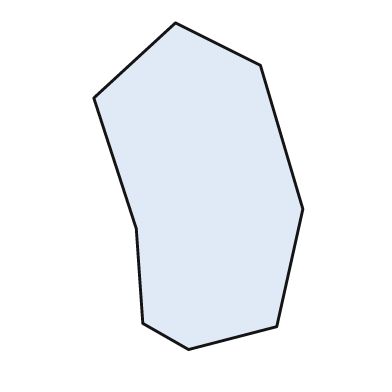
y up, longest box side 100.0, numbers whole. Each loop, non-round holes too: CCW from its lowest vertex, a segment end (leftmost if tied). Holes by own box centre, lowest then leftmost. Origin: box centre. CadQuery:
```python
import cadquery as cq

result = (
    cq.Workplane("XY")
    .moveTo(-3.0, -50.0)
    .lineTo(24.0, -43.0)
    .lineTo(32.0, -7.0)
    .lineTo(19.0, 37.0)
    .lineTo(-7.0, 50.0)
    .lineTo(-32.0, 27.0)
    .lineTo(-19.0, -13.0)
    .lineTo(-17.0, -42.0)
    .close()
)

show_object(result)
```